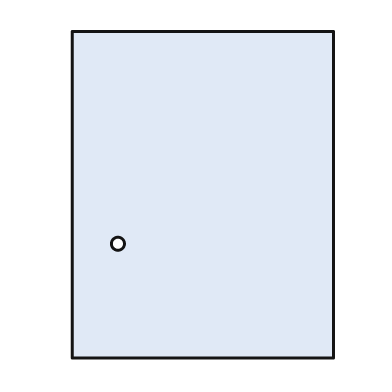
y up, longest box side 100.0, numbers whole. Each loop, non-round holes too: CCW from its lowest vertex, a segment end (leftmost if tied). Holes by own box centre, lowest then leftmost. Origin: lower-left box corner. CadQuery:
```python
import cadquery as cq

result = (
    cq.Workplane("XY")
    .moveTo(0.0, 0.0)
    .lineTo(80.0, 0.0)
    .lineTo(80.0, 100.0)
    .lineTo(0.0, 100.0)
    .close()
    .moveTo(14.0, 35.0)
    .circle(2.0)
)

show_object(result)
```